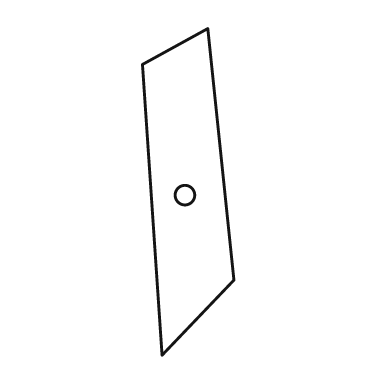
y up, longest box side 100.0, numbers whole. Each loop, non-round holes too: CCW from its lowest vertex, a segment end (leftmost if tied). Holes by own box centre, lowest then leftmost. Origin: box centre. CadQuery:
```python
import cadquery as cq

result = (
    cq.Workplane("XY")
    .moveTo(-8.0, -50.0)
    .lineTo(14.0, -27.0)
    .lineTo(6.0, 50.0)
    .lineTo(-14.0, 39.0)
    .close()
    .moveTo(-1.0, -1.0)
    .circle(3.0)
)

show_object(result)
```